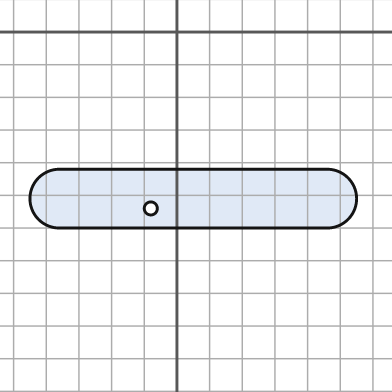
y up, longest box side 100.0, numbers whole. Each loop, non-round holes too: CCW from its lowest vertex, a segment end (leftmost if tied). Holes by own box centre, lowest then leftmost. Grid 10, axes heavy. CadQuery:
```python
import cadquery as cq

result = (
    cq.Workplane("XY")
    .moveTo(-36.0, -60.0)
    .lineTo(46.0, -60.0)
    .threePointArc((55.0, -51.0), (46.0, -42.0))
    .lineTo(-36.0, -42.0)
    .threePointArc((-45.0, -51.0), (-36.0, -60.0))
    .close()
    .moveTo(-8.0, -54.0)
    .circle(2.0)
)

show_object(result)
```